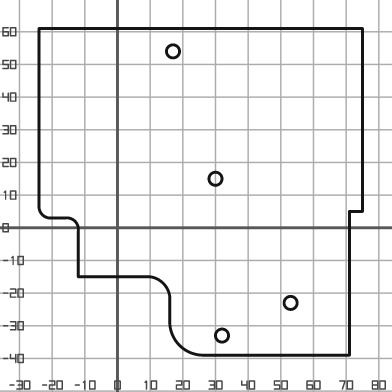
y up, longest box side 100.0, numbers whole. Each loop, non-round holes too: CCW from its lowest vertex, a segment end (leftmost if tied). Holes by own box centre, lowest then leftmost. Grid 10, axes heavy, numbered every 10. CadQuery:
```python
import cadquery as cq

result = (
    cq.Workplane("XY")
    .moveTo(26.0, -39.0)
    .lineTo(71.0, -39.0)
    .lineTo(71.0, 5.0)
    .lineTo(75.0, 5.0)
    .lineTo(75.0, 61.0)
    .lineTo(-24.0, 61.0)
    .lineTo(-24.0, 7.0)
    .threePointArc((-23.0, 4.0), (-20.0, 3.0))
    .lineTo(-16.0, 3.0)
    .threePointArc((-13.0, 2.0), (-12.0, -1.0))
    .lineTo(-12.0, -15.0)
    .lineTo(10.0, -15.0)
    .threePointArc((14.0, -17.0), (16.0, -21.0))
    .lineTo(16.0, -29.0)
    .threePointArc((19.0, -36.0), (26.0, -39.0))
    .close()
    .moveTo(32.0, -33.0)
    .circle(2.0)
    .moveTo(53.0, -23.0)
    .circle(2.0)
    .moveTo(30.0, 15.0)
    .circle(2.0)
    .moveTo(17.0, 54.0)
    .circle(2.0)
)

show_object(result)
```